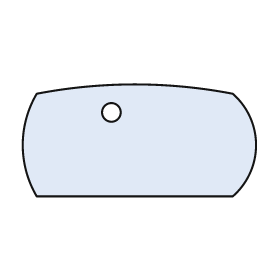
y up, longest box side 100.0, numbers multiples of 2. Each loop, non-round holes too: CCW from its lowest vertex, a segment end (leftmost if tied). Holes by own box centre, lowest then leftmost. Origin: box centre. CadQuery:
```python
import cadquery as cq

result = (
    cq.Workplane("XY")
    .moveTo(-44.0, -24.0)
    .lineTo(40.0, -24.0)
    .threePointArc((50.0, -2.0), (40.0, 20.0))
    .threePointArc((-2.0, 24.0), (-44.0, 20.0))
    .threePointArc((-50.0, -2.0), (-44.0, -24.0))
    .close()
    .moveTo(-12.0, 12.0)
    .circle(4.0)
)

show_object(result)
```